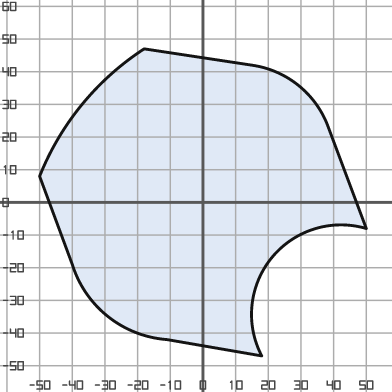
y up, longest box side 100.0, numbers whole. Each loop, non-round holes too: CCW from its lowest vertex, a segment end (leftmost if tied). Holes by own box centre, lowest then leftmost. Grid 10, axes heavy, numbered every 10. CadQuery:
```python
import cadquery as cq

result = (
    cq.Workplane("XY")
    .moveTo(18.0, -47.0)
    .threePointArc((21.0, -17.0), (50.0, -8.0))
    .lineTo(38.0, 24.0)
    .threePointArc((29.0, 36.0), (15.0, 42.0))
    .lineTo(-18.0, 47.0)
    .threePointArc((-37.0, 30.0), (-50.0, 8.0))
    .lineTo(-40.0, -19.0)
    .threePointArc((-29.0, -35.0), (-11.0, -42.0))
    .close()
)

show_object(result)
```